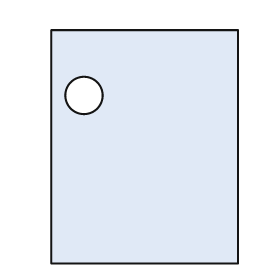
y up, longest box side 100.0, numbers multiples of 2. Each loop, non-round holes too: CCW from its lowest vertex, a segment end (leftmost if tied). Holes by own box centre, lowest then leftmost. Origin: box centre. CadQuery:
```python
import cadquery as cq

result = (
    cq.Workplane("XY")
    .moveTo(-40.0, -50.0)
    .lineTo(40.0, -50.0)
    .lineTo(40.0, 50.0)
    .lineTo(-40.0, 50.0)
    .close()
    .moveTo(-26.0, 22.0)
    .circle(8.0)
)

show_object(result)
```